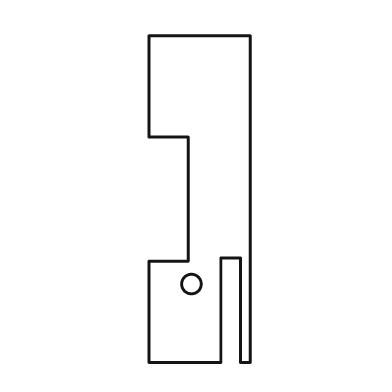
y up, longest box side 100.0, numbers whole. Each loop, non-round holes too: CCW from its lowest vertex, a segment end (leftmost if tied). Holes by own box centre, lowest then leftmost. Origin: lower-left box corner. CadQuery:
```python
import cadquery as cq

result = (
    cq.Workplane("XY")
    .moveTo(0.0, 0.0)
    .lineTo(22.0, 0.0)
    .lineTo(22.0, 32.0)
    .lineTo(28.0, 32.0)
    .lineTo(28.0, 0.0)
    .lineTo(31.0, 0.0)
    .lineTo(31.0, 100.0)
    .lineTo(0.0, 100.0)
    .lineTo(0.0, 69.0)
    .lineTo(12.0, 69.0)
    .lineTo(12.0, 31.0)
    .lineTo(0.0, 31.0)
    .close()
    .moveTo(13.0, 24.0)
    .circle(3.0)
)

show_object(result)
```